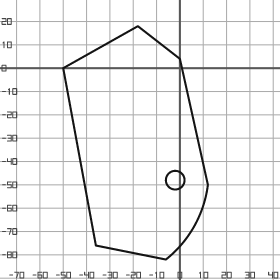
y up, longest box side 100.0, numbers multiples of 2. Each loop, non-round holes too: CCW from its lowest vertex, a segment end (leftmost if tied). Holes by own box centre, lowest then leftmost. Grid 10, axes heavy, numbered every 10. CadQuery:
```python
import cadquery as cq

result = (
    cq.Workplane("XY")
    .moveTo(-6.0, -82.0)
    .threePointArc((6.0, -68.0), (12.0, -50.0))
    .lineTo(0.0, 4.0)
    .lineTo(-18.0, 18.0)
    .lineTo(-50.0, 0.0)
    .lineTo(-36.0, -76.0)
    .close()
    .moveTo(-2.0, -48.0)
    .circle(4.0)
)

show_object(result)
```